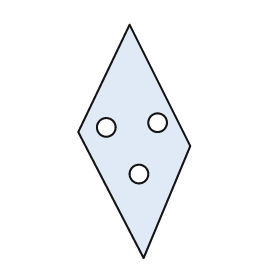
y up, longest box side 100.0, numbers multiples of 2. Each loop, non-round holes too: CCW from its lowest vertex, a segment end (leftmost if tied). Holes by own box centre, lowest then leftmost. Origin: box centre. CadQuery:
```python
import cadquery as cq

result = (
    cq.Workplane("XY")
    .moveTo(4.0, -50.0)
    .lineTo(24.0, -2.0)
    .lineTo(-2.0, 50.0)
    .lineTo(-24.0, 4.0)
    .close()
    .moveTo(2.0, -14.0)
    .circle(4.0)
    .moveTo(-12.0, 6.0)
    .circle(4.0)
    .moveTo(10.0, 8.0)
    .circle(4.0)
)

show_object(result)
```